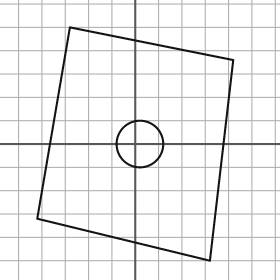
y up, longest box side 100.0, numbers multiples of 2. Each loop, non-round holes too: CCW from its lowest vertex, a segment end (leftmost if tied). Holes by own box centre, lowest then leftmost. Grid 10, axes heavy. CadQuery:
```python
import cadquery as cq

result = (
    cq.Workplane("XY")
    .moveTo(32.0, -50.0)
    .lineTo(42.0, 36.0)
    .lineTo(-28.0, 50.0)
    .lineTo(-42.0, -32.0)
    .close()
    .moveTo(2.0, 0.0)
    .circle(10.0)
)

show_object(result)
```